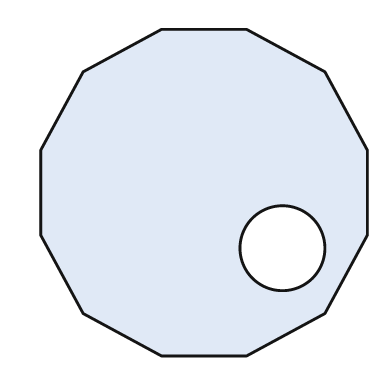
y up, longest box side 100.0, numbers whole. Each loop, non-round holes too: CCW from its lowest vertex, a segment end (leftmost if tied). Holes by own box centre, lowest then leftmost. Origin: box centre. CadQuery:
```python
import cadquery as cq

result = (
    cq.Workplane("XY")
    .moveTo(-13.0, -50.0)
    .lineTo(13.0, -50.0)
    .lineTo(37.0, -37.0)
    .lineTo(50.0, -13.0)
    .lineTo(50.0, 13.0)
    .lineTo(37.0, 37.0)
    .lineTo(13.0, 50.0)
    .lineTo(-13.0, 50.0)
    .lineTo(-37.0, 37.0)
    .lineTo(-50.0, 13.0)
    .lineTo(-50.0, -13.0)
    .lineTo(-37.0, -37.0)
    .close()
    .moveTo(24.0, -17.0)
    .circle(13.0)
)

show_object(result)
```